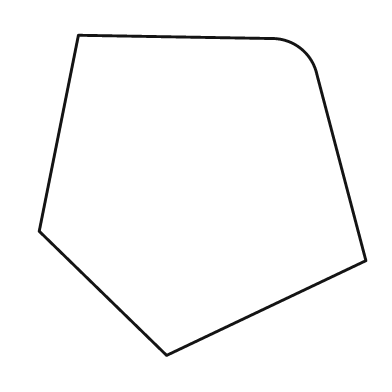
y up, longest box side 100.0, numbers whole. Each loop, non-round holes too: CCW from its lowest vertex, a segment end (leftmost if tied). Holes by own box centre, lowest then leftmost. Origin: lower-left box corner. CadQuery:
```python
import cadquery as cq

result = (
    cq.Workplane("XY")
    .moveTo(39.0, 0.0)
    .lineTo(100.0, 29.0)
    .lineTo(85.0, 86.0)
    .threePointArc((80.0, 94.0), (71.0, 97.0))
    .lineTo(12.0, 98.0)
    .lineTo(0.0, 38.0)
    .close()
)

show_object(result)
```